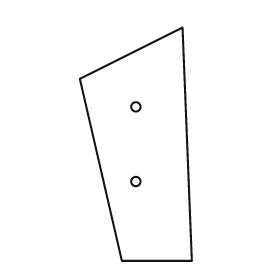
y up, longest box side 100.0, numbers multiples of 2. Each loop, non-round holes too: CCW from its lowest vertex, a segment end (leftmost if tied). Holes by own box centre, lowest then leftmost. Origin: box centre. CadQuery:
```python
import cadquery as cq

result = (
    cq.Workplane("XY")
    .moveTo(-6.0, -50.0)
    .lineTo(24.0, -50.0)
    .lineTo(20.0, 50.0)
    .lineTo(-24.0, 28.0)
    .close()
    .moveTo(0.0, -16.0)
    .circle(2.0)
    .moveTo(0.0, 16.0)
    .circle(2.0)
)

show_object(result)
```